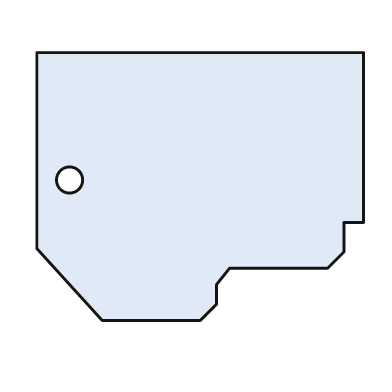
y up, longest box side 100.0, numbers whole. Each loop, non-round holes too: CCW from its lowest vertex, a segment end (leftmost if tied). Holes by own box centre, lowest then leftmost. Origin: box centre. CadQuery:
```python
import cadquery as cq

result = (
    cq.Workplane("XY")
    .moveTo(-30.0, -41.0)
    .lineTo(0.0, -41.0)
    .lineTo(5.0, -36.0)
    .lineTo(5.0, -30.0)
    .lineTo(9.0, -25.0)
    .lineTo(39.0, -25.0)
    .lineTo(44.0, -20.0)
    .lineTo(44.0, -11.0)
    .lineTo(50.0, -11.0)
    .lineTo(50.0, 41.0)
    .lineTo(-50.0, 41.0)
    .lineTo(-50.0, -19.0)
    .close()
    .moveTo(-40.0, 2.0)
    .circle(4.0)
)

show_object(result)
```